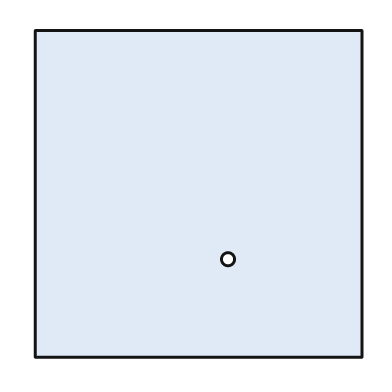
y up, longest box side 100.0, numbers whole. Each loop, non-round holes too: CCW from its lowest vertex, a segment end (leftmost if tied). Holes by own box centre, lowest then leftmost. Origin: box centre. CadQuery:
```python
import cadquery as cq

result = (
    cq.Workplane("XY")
    .moveTo(-50.0, -50.0)
    .lineTo(50.0, -50.0)
    .lineTo(50.0, 50.0)
    .lineTo(-50.0, 50.0)
    .close()
    .moveTo(9.0, -20.0)
    .circle(2.0)
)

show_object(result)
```